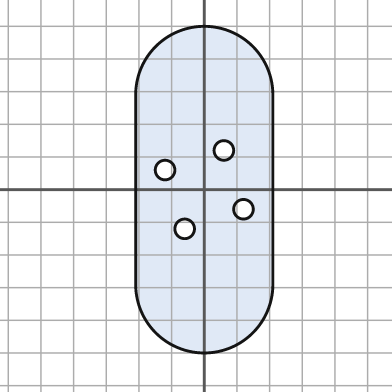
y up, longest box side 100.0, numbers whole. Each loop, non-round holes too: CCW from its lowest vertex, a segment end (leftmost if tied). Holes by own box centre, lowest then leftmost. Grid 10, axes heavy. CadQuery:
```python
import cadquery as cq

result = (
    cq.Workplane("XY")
    .moveTo(-21.0, -29.0)
    .threePointArc((0.0, -50.0), (21.0, -29.0))
    .lineTo(21.0, 29.0)
    .threePointArc((0.0, 50.0), (-21.0, 29.0))
    .close()
    .moveTo(-6.0, -12.0)
    .circle(3.0)
    .moveTo(12.0, -6.0)
    .circle(3.0)
    .moveTo(-12.0, 6.0)
    .circle(3.0)
    .moveTo(6.0, 12.0)
    .circle(3.0)
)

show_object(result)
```